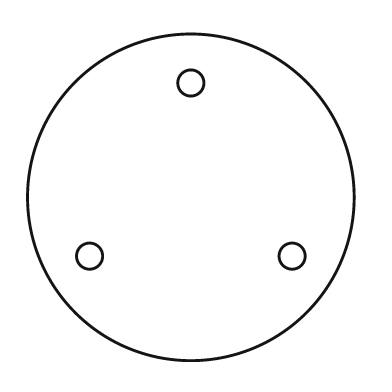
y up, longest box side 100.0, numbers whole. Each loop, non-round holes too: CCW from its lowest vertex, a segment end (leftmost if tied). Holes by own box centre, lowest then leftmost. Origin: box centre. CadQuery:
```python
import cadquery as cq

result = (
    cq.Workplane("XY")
    .moveTo(0.0, 0.0)
    .circle(50.0)
    .moveTo(-31.0, -18.0)
    .circle(4.0)
    .moveTo(31.0, -18.0)
    .circle(4.0)
    .moveTo(0.0, 35.0)
    .circle(4.0)
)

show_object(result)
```